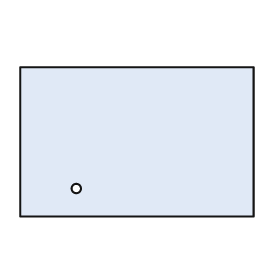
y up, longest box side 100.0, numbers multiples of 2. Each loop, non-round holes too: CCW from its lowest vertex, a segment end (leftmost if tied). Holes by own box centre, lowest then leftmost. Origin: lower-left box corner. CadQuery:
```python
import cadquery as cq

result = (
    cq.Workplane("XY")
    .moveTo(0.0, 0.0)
    .lineTo(100.0, 0.0)
    .lineTo(100.0, 64.0)
    .lineTo(0.0, 64.0)
    .close()
    .moveTo(24.0, 12.0)
    .circle(2.0)
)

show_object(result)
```